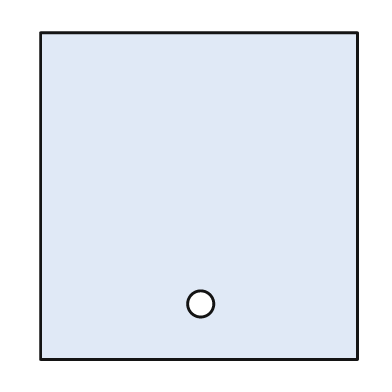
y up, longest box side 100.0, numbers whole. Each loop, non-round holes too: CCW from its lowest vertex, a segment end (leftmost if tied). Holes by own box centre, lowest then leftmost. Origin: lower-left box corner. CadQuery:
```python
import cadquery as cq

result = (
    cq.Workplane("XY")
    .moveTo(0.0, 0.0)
    .lineTo(97.0, 0.0)
    .lineTo(97.0, 100.0)
    .lineTo(0.0, 100.0)
    .close()
    .moveTo(49.0, 17.0)
    .circle(4.0)
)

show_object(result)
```